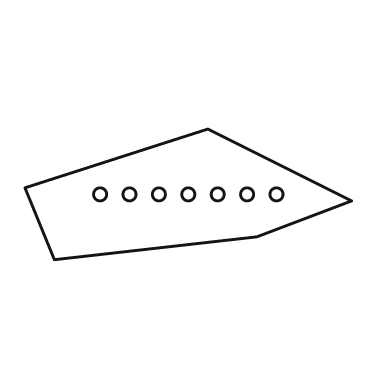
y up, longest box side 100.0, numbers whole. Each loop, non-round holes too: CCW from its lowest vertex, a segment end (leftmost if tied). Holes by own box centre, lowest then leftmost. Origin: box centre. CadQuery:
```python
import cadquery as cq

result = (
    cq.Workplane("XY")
    .moveTo(-41.0, -20.0)
    .lineTo(21.0, -13.0)
    .lineTo(50.0, -2.0)
    .lineTo(6.0, 20.0)
    .lineTo(-50.0, 2.0)
    .close()
    .moveTo(-27.0, 0.0)
    .circle(2.0)
    .moveTo(-18.0, 0.0)
    .circle(2.0)
    .moveTo(-9.0, 0.0)
    .circle(2.0)
    .moveTo(0.0, 0.0)
    .circle(2.0)
    .moveTo(9.0, 0.0)
    .circle(2.0)
    .moveTo(18.0, 0.0)
    .circle(2.0)
    .moveTo(27.0, 0.0)
    .circle(2.0)
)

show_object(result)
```